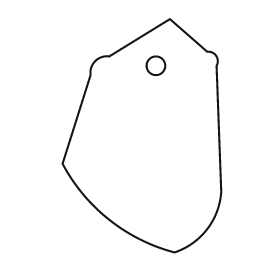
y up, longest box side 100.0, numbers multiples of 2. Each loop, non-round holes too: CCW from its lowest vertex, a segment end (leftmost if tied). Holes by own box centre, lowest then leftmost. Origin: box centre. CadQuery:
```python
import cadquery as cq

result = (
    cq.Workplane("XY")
    .moveTo(14.0, -50.0)
    .threePointArc((28.0, -40.0), (34.0, -24.0))
    .lineTo(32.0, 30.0)
    .threePointArc((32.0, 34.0), (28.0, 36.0))
    .lineTo(12.0, 50.0)
    .lineTo(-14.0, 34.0)
    .threePointArc((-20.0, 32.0), (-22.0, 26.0))
    .lineTo(-34.0, -12.0)
    .threePointArc((-14.0, -36.0), (14.0, -50.0))
    .close()
    .moveTo(6.0, 30.0)
    .circle(4.0)
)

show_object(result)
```